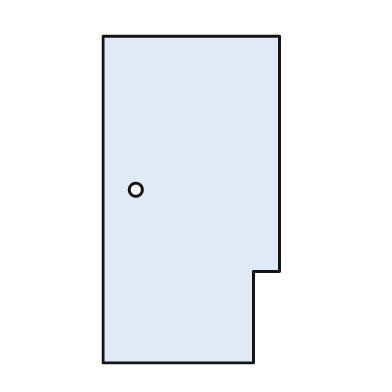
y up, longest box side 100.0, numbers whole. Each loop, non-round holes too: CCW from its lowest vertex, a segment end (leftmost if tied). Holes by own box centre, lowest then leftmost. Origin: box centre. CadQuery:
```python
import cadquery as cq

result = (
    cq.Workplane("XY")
    .moveTo(-27.0, -50.0)
    .lineTo(19.0, -50.0)
    .lineTo(19.0, -22.0)
    .lineTo(27.0, -22.0)
    .lineTo(27.0, 50.0)
    .lineTo(-27.0, 50.0)
    .close()
    .moveTo(-17.0, 3.0)
    .circle(2.0)
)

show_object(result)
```